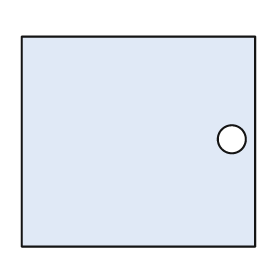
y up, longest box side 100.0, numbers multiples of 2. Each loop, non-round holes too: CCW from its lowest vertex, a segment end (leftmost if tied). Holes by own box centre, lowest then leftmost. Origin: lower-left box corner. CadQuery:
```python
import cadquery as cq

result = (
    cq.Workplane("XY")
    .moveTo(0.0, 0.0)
    .lineTo(100.0, 0.0)
    .lineTo(100.0, 90.0)
    .lineTo(0.0, 90.0)
    .close()
    .moveTo(90.0, 46.0)
    .circle(6.0)
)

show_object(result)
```